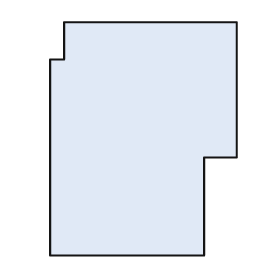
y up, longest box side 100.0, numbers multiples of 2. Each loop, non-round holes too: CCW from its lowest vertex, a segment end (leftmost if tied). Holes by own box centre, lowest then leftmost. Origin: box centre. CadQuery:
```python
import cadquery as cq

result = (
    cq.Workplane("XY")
    .moveTo(-40.0, -50.0)
    .lineTo(26.0, -50.0)
    .lineTo(26.0, -8.0)
    .lineTo(40.0, -8.0)
    .lineTo(40.0, 50.0)
    .lineTo(-34.0, 50.0)
    .lineTo(-34.0, 34.0)
    .lineTo(-40.0, 34.0)
    .close()
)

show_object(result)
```